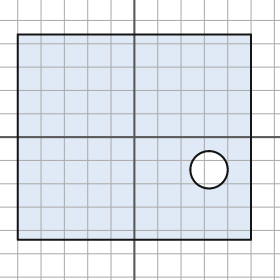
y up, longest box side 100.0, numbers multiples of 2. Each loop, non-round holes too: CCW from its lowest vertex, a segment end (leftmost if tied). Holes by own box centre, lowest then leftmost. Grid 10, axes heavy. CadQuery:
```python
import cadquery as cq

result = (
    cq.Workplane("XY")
    .moveTo(-50.0, -44.0)
    .lineTo(50.0, -44.0)
    .lineTo(50.0, 44.0)
    .lineTo(-50.0, 44.0)
    .close()
    .moveTo(32.0, -14.0)
    .circle(8.0)
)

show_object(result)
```